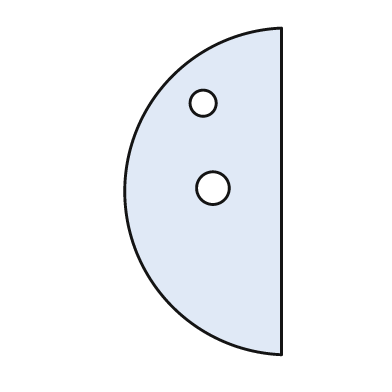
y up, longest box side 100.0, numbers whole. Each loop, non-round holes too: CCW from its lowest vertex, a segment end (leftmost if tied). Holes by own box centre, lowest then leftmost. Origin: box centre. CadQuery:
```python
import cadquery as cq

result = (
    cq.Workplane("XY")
    .moveTo(24.0, -50.0)
    .lineTo(24.0, 50.0)
    .threePointArc((-24.0, 0.0), (24.0, -50.0))
    .close()
    .moveTo(3.0, 1.0)
    .circle(5.0)
    .moveTo(0.0, 27.0)
    .circle(4.0)
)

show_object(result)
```